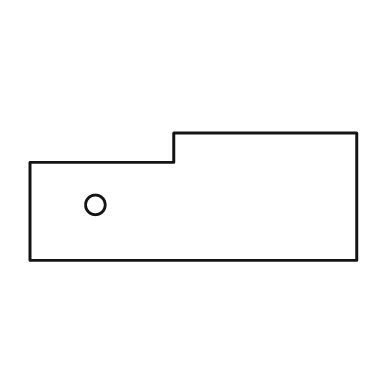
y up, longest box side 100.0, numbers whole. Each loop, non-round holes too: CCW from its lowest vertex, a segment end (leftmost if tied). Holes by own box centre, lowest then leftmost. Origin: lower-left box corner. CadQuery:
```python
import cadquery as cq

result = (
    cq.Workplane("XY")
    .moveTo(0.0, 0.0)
    .lineTo(100.0, 0.0)
    .lineTo(100.0, 39.0)
    .lineTo(44.0, 39.0)
    .lineTo(44.0, 30.0)
    .lineTo(0.0, 30.0)
    .close()
    .moveTo(20.0, 17.0)
    .circle(3.0)
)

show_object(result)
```